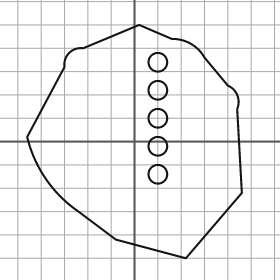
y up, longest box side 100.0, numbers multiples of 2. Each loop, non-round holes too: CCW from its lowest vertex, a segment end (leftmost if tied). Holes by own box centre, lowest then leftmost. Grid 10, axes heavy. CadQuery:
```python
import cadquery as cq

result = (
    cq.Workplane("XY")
    .moveTo(22.0, -50.0)
    .lineTo(46.0, -22.0)
    .lineTo(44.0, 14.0)
    .threePointArc((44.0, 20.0), (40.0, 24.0))
    .lineTo(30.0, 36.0)
    .threePointArc((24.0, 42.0), (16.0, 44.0))
    .lineTo(2.0, 50.0)
    .lineTo(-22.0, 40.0)
    .threePointArc((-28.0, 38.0), (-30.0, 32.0))
    .lineTo(-46.0, 2.0)
    .threePointArc((-38.0, -16.0), (-24.0, -30.0))
    .lineTo(-8.0, -42.0)
    .close()
    .moveTo(10.0, -14.0)
    .circle(4.0)
    .moveTo(10.0, -2.0)
    .circle(4.0)
    .moveTo(10.0, 10.0)
    .circle(4.0)
    .moveTo(10.0, 22.0)
    .circle(4.0)
    .moveTo(10.0, 34.0)
    .circle(4.0)
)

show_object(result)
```